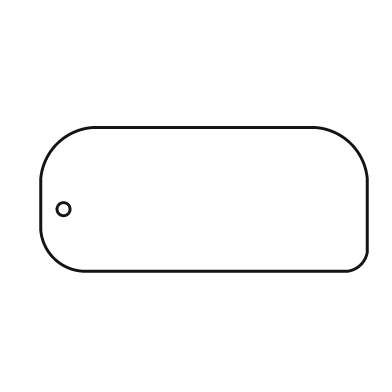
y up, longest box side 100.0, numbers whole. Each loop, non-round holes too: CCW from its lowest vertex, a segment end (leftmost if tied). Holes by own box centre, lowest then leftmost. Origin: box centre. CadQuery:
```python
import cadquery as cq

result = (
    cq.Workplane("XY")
    .moveTo(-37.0, -22.0)
    .lineTo(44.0, -22.0)
    .threePointArc((48.0, -20.0), (50.0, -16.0))
    .lineTo(50.0, 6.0)
    .threePointArc((45.0, 17.0), (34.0, 22.0))
    .lineTo(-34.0, 22.0)
    .threePointArc((-45.0, 17.0), (-50.0, 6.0))
    .lineTo(-50.0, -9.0)
    .threePointArc((-46.0, -18.0), (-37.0, -22.0))
    .close()
    .moveTo(-43.0, -3.0)
    .circle(2.0)
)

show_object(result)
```